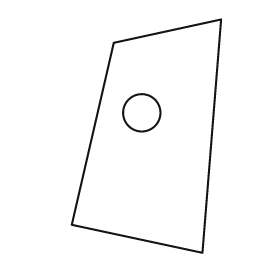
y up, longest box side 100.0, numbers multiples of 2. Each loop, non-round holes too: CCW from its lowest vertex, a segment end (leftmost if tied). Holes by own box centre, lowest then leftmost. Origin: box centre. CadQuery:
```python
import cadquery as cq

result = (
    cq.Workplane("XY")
    .moveTo(24.0, -50.0)
    .lineTo(32.0, 50.0)
    .lineTo(-14.0, 40.0)
    .lineTo(-32.0, -38.0)
    .close()
    .moveTo(-2.0, 10.0)
    .circle(8.0)
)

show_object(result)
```